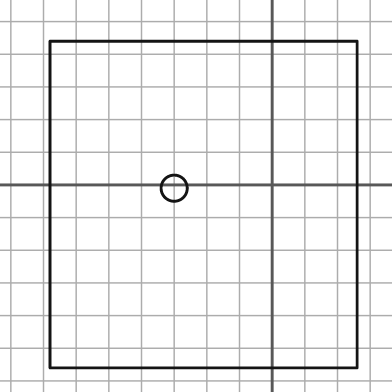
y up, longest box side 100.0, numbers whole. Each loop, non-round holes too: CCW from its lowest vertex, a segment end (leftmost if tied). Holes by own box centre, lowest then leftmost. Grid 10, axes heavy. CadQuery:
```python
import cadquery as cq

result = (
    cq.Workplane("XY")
    .moveTo(-68.0, -56.0)
    .lineTo(26.0, -56.0)
    .lineTo(26.0, 44.0)
    .lineTo(-68.0, 44.0)
    .close()
    .moveTo(-30.0, -1.0)
    .circle(4.0)
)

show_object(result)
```